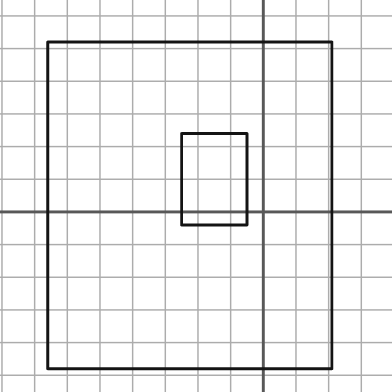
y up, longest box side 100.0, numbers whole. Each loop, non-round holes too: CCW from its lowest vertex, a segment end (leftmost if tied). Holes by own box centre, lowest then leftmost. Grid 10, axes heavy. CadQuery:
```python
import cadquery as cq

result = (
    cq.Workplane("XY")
    .moveTo(-66.0, -48.0)
    .lineTo(21.0, -48.0)
    .lineTo(21.0, 52.0)
    .lineTo(-66.0, 52.0)
    .close()
    .moveTo(-25.0, -4.0)
    .lineTo(-5.0, -4.0)
    .lineTo(-5.0, 24.0)
    .lineTo(-25.0, 24.0)
    .close()
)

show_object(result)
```